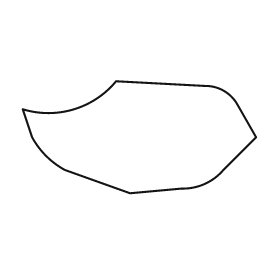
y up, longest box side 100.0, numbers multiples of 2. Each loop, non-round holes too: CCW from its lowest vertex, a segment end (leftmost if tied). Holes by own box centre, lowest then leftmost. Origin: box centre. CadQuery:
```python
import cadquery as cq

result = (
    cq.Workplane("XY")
    .moveTo(-4.0, -24.0)
    .lineTo(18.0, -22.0)
    .threePointArc((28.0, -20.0), (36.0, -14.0))
    .lineTo(50.0, 0.0)
    .lineTo(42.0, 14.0)
    .threePointArc((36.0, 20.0), (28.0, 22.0))
    .lineTo(-10.0, 24.0)
    .threePointArc((-28.0, 12.0), (-50.0, 12.0))
    .lineTo(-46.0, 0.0)
    .threePointArc((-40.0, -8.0), (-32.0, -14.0))
    .close()
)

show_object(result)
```